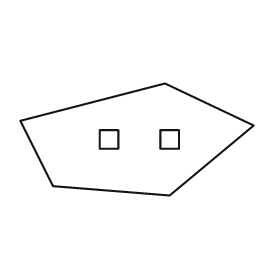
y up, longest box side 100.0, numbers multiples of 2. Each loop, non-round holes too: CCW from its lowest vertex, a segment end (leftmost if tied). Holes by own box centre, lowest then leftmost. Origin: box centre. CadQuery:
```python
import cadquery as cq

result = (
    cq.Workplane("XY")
    .moveTo(14.0, -24.0)
    .lineTo(50.0, 6.0)
    .lineTo(12.0, 24.0)
    .lineTo(-50.0, 8.0)
    .lineTo(-36.0, -20.0)
    .close()
    .moveTo(-16.0, -4.0)
    .lineTo(-8.0, -4.0)
    .lineTo(-8.0, 4.0)
    .lineTo(-16.0, 4.0)
    .close()
    .moveTo(10.0, -4.0)
    .lineTo(18.0, -4.0)
    .lineTo(18.0, 4.0)
    .lineTo(10.0, 4.0)
    .close()
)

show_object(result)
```